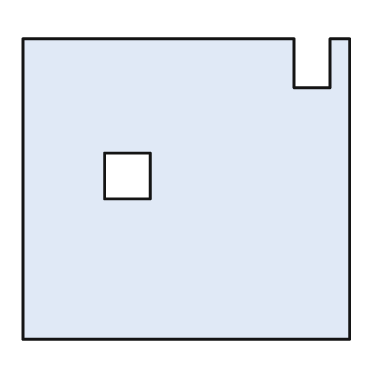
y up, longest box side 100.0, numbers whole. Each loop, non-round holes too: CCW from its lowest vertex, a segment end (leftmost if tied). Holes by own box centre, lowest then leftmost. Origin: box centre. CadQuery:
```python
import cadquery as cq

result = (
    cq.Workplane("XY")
    .moveTo(-50.0, -46.0)
    .lineTo(50.0, -46.0)
    .lineTo(50.0, 46.0)
    .lineTo(44.0, 46.0)
    .lineTo(44.0, 31.0)
    .lineTo(33.0, 31.0)
    .lineTo(33.0, 46.0)
    .lineTo(-50.0, 46.0)
    .close()
    .moveTo(-25.0, -3.0)
    .lineTo(-11.0, -3.0)
    .lineTo(-11.0, 11.0)
    .lineTo(-25.0, 11.0)
    .close()
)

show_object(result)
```